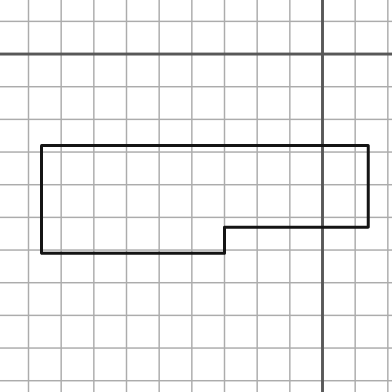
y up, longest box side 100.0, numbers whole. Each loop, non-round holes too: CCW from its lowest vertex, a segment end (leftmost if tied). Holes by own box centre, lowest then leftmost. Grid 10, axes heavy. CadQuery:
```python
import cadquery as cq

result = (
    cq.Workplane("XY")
    .moveTo(-86.0, -61.0)
    .lineTo(-30.0, -61.0)
    .lineTo(-30.0, -53.0)
    .lineTo(14.0, -53.0)
    .lineTo(14.0, -28.0)
    .lineTo(-86.0, -28.0)
    .close()
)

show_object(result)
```